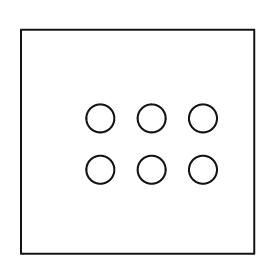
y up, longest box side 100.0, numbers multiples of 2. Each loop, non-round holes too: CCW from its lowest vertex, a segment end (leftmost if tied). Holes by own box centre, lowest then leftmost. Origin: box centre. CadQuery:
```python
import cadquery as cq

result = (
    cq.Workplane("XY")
    .moveTo(-50.0, -48.0)
    .lineTo(50.0, -48.0)
    .lineTo(50.0, 48.0)
    .lineTo(-50.0, 48.0)
    .close()
    .moveTo(-16.0, -12.0)
    .circle(6.0)
    .moveTo(6.0, -12.0)
    .circle(6.0)
    .moveTo(28.0, -12.0)
    .circle(6.0)
    .moveTo(-16.0, 10.0)
    .circle(6.0)
    .moveTo(6.0, 10.0)
    .circle(6.0)
    .moveTo(28.0, 10.0)
    .circle(6.0)
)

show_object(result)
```